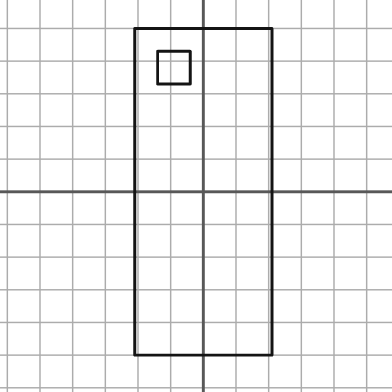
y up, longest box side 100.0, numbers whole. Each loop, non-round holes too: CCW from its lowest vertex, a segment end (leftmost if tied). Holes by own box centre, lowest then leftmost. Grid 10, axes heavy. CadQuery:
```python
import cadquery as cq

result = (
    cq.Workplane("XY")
    .moveTo(-21.0, -50.0)
    .lineTo(21.0, -50.0)
    .lineTo(21.0, 50.0)
    .lineTo(-21.0, 50.0)
    .close()
    .moveTo(-14.0, 33.0)
    .lineTo(-4.0, 33.0)
    .lineTo(-4.0, 43.0)
    .lineTo(-14.0, 43.0)
    .close()
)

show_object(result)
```